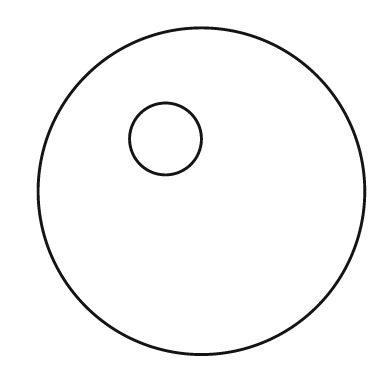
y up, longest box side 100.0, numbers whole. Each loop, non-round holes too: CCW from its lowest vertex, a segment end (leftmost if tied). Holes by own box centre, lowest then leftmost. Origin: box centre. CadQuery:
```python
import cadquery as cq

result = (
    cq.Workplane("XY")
    .moveTo(0.0, 0.0)
    .circle(50.0)
    .moveTo(-11.0, 16.0)
    .circle(11.0)
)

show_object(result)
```